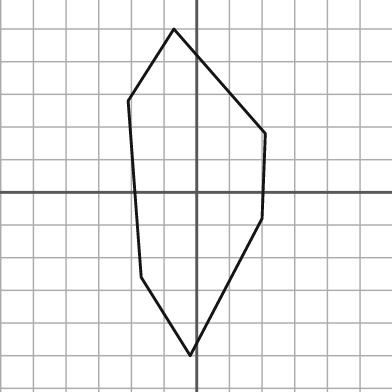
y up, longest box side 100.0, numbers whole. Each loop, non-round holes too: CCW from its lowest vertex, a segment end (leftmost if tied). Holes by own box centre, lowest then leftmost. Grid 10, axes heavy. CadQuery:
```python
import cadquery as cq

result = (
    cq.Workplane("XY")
    .moveTo(-2.0, -50.0)
    .lineTo(20.0, -8.0)
    .lineTo(21.0, 18.0)
    .lineTo(-7.0, 50.0)
    .lineTo(-21.0, 28.0)
    .lineTo(-17.0, -26.0)
    .close()
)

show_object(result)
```